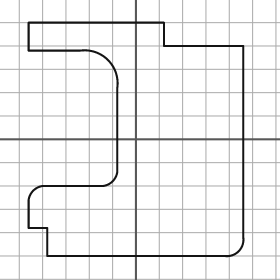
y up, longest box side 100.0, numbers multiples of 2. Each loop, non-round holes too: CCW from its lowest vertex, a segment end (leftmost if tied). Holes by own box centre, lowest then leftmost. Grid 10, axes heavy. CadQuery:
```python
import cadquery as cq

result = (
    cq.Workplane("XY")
    .moveTo(-38.0, -50.0)
    .lineTo(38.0, -50.0)
    .threePointArc((44.0, -48.0), (46.0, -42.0))
    .lineTo(46.0, 40.0)
    .lineTo(12.0, 40.0)
    .lineTo(12.0, 50.0)
    .lineTo(-46.0, 50.0)
    .lineTo(-46.0, 38.0)
    .lineTo(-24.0, 38.0)
    .threePointArc((-12.0, 34.0), (-8.0, 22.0))
    .lineTo(-8.0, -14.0)
    .threePointArc((-10.0, -18.0), (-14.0, -20.0))
    .lineTo(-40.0, -20.0)
    .threePointArc((-44.0, -22.0), (-46.0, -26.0))
    .lineTo(-46.0, -38.0)
    .lineTo(-38.0, -38.0)
    .close()
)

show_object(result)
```